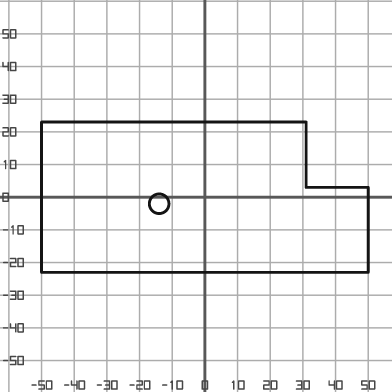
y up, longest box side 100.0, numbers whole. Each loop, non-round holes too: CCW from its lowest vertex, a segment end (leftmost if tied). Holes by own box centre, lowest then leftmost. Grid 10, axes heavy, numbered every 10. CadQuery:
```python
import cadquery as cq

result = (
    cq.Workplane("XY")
    .moveTo(-50.0, -23.0)
    .lineTo(50.0, -23.0)
    .lineTo(50.0, 3.0)
    .lineTo(31.0, 3.0)
    .lineTo(31.0, 23.0)
    .lineTo(-50.0, 23.0)
    .close()
    .moveTo(-14.0, -2.0)
    .circle(3.0)
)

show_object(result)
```